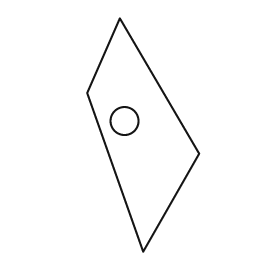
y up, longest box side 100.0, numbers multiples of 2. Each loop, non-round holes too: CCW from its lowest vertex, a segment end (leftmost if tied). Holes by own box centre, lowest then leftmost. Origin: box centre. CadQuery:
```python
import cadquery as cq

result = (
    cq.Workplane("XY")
    .moveTo(0.0, -50.0)
    .lineTo(24.0, -8.0)
    .lineTo(-10.0, 50.0)
    .lineTo(-24.0, 18.0)
    .close()
    .moveTo(-8.0, 6.0)
    .circle(6.0)
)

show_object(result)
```